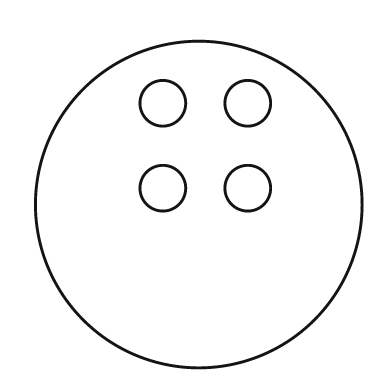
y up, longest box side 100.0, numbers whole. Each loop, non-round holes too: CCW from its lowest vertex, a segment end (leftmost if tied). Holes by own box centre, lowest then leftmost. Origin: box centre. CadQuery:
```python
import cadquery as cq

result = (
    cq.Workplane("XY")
    .moveTo(0.0, 0.0)
    .circle(50.0)
    .moveTo(-11.0, 5.0)
    .circle(7.0)
    .moveTo(15.0, 5.0)
    .circle(7.0)
    .moveTo(-11.0, 31.0)
    .circle(7.0)
    .moveTo(15.0, 31.0)
    .circle(7.0)
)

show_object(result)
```